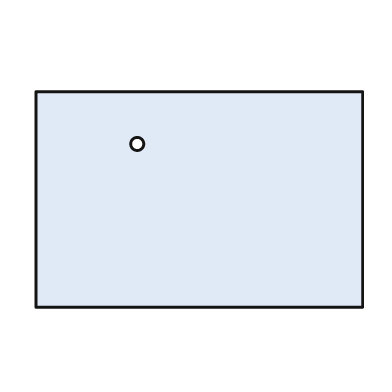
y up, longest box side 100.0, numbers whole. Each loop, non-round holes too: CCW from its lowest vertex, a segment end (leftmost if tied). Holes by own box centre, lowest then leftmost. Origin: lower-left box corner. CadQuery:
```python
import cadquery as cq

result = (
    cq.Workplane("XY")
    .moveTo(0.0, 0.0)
    .lineTo(100.0, 0.0)
    .lineTo(100.0, 66.0)
    .lineTo(0.0, 66.0)
    .close()
    .moveTo(31.0, 50.0)
    .circle(2.0)
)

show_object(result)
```